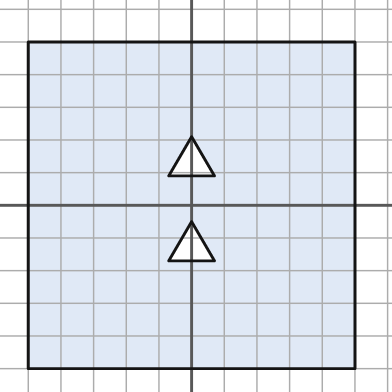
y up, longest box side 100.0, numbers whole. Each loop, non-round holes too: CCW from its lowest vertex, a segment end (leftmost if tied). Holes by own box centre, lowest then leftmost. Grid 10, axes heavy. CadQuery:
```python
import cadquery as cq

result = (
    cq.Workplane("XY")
    .moveTo(-50.0, -50.0)
    .lineTo(50.0, -50.0)
    .lineTo(50.0, 50.0)
    .lineTo(-50.0, 50.0)
    .close()
    .moveTo(-7.0, -17.0)
    .lineTo(7.0, -17.0)
    .lineTo(0.0, -5.0)
    .close()
    .moveTo(-7.0, 9.0)
    .lineTo(7.0, 9.0)
    .lineTo(0.0, 21.0)
    .close()
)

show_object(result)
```